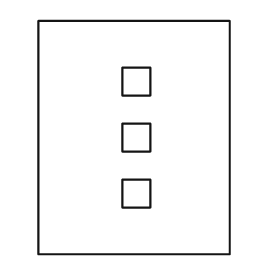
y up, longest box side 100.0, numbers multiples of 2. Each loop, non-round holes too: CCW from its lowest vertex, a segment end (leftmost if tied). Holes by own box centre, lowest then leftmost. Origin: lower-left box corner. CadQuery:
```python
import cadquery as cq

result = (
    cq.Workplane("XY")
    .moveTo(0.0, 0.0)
    .lineTo(82.0, 0.0)
    .lineTo(82.0, 100.0)
    .lineTo(0.0, 100.0)
    .close()
    .moveTo(36.0, 20.0)
    .lineTo(48.0, 20.0)
    .lineTo(48.0, 32.0)
    .lineTo(36.0, 32.0)
    .close()
    .moveTo(36.0, 44.0)
    .lineTo(48.0, 44.0)
    .lineTo(48.0, 56.0)
    .lineTo(36.0, 56.0)
    .close()
    .moveTo(36.0, 68.0)
    .lineTo(48.0, 68.0)
    .lineTo(48.0, 80.0)
    .lineTo(36.0, 80.0)
    .close()
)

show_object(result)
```